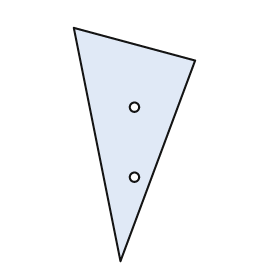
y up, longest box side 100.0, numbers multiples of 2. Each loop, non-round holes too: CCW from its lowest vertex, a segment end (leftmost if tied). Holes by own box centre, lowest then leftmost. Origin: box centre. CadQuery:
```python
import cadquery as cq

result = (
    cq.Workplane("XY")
    .moveTo(-6.0, -50.0)
    .lineTo(26.0, 36.0)
    .lineTo(-26.0, 50.0)
    .close()
    .moveTo(0.0, -14.0)
    .circle(2.0)
    .moveTo(0.0, 16.0)
    .circle(2.0)
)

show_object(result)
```